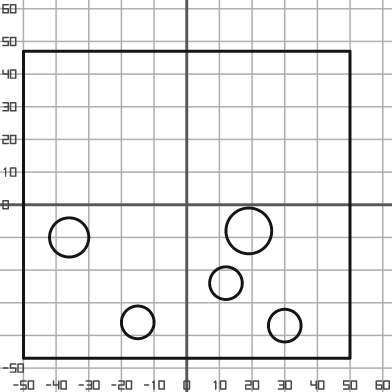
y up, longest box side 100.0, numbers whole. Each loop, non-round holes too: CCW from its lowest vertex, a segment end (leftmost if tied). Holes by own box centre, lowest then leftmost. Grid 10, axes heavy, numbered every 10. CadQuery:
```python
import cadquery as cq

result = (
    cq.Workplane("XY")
    .moveTo(-50.0, -47.0)
    .lineTo(50.0, -47.0)
    .lineTo(50.0, 47.0)
    .lineTo(-50.0, 47.0)
    .close()
    .moveTo(30.0, -37.0)
    .circle(5.0)
    .moveTo(-15.0, -36.0)
    .circle(5.0)
    .moveTo(12.0, -24.0)
    .circle(5.0)
    .moveTo(-36.0, -10.0)
    .circle(6.0)
    .moveTo(19.0, -8.0)
    .circle(7.0)
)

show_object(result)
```